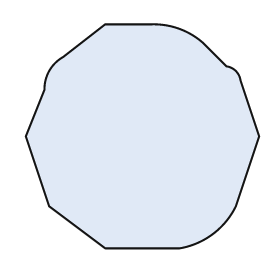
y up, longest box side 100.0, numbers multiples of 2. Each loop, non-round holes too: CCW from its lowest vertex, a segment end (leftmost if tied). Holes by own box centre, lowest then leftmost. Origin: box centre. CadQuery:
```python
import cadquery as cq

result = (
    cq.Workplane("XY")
    .moveTo(-16.0, -48.0)
    .lineTo(16.0, -48.0)
    .threePointArc((30.0, -42.0), (40.0, -30.0))
    .lineTo(50.0, 0.0)
    .lineTo(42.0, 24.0)
    .threePointArc((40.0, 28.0), (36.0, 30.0))
    .lineTo(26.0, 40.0)
    .threePointArc((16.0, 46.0), (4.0, 48.0))
    .lineTo(-16.0, 48.0)
    .lineTo(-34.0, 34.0)
    .threePointArc((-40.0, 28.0), (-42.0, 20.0))
    .lineTo(-50.0, 0.0)
    .lineTo(-40.0, -30.0)
    .close()
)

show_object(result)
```